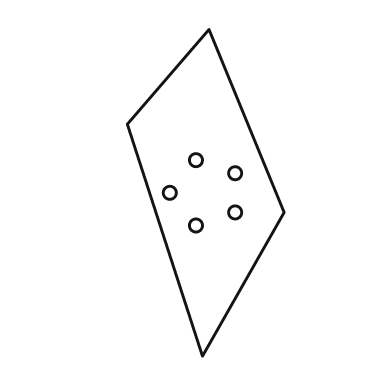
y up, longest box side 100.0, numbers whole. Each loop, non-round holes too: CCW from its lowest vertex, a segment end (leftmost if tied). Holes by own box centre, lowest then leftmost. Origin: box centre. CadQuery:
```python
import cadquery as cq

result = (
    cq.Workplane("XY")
    .moveTo(-1.0, -50.0)
    .lineTo(24.0, -6.0)
    .lineTo(1.0, 50.0)
    .lineTo(-24.0, 21.0)
    .close()
    .moveTo(-3.0, -10.0)
    .circle(2.0)
    .moveTo(9.0, -6.0)
    .circle(2.0)
    .moveTo(-11.0, 0.0)
    .circle(2.0)
    .moveTo(9.0, 6.0)
    .circle(2.0)
    .moveTo(-3.0, 10.0)
    .circle(2.0)
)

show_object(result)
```